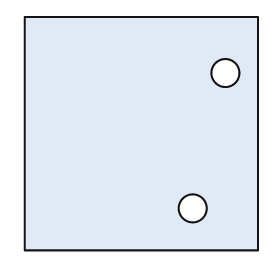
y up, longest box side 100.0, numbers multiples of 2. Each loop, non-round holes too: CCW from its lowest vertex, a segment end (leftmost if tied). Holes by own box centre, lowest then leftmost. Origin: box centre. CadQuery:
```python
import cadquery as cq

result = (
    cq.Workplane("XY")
    .moveTo(-50.0, -50.0)
    .lineTo(50.0, -50.0)
    .lineTo(50.0, 50.0)
    .lineTo(-50.0, 50.0)
    .close()
    .moveTo(22.0, -32.0)
    .circle(6.0)
    .moveTo(36.0, 26.0)
    .circle(6.0)
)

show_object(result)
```